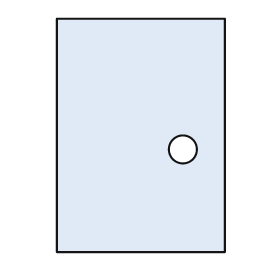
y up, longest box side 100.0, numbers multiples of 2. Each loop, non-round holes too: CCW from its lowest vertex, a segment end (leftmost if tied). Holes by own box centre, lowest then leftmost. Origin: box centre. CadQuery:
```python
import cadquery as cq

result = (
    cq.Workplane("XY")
    .moveTo(-36.0, -50.0)
    .lineTo(36.0, -50.0)
    .lineTo(36.0, 50.0)
    .lineTo(-36.0, 50.0)
    .close()
    .moveTo(18.0, -6.0)
    .circle(6.0)
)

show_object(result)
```